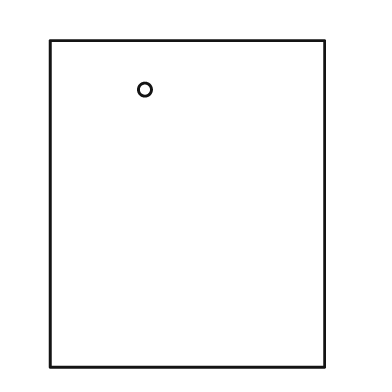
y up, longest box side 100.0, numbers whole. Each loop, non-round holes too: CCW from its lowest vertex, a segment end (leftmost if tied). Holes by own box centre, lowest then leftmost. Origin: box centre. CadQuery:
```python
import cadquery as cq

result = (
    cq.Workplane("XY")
    .moveTo(-42.0, -50.0)
    .lineTo(42.0, -50.0)
    .lineTo(42.0, 50.0)
    .lineTo(-42.0, 50.0)
    .close()
    .moveTo(-13.0, 35.0)
    .circle(2.0)
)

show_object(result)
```